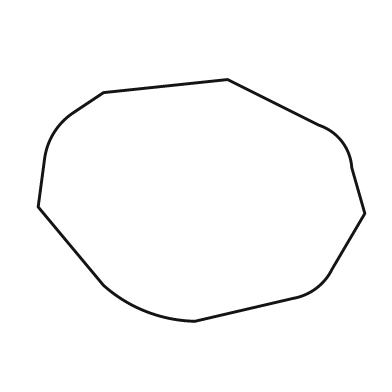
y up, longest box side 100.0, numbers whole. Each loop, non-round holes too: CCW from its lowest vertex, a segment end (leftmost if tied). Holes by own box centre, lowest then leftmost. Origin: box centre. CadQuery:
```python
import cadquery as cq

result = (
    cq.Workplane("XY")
    .moveTo(-2.0, -37.0)
    .lineTo(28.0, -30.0)
    .threePointArc((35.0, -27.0), (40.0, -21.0))
    .lineTo(50.0, -4.0)
    .lineTo(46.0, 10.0)
    .threePointArc((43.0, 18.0), (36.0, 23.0))
    .lineTo(8.0, 37.0)
    .lineTo(-30.0, 33.0)
    .lineTo(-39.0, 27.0)
    .threePointArc((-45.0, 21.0), (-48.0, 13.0))
    .lineTo(-50.0, -2.0)
    .lineTo(-30.0, -26.0)
    .threePointArc((-17.0, -34.0), (-2.0, -37.0))
    .close()
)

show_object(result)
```